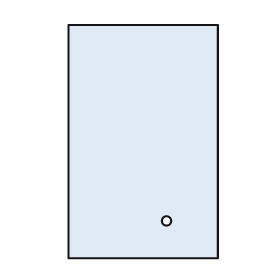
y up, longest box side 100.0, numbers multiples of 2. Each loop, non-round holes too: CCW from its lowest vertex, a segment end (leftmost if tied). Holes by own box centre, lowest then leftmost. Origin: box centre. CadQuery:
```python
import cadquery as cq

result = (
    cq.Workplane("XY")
    .moveTo(-32.0, -50.0)
    .lineTo(32.0, -50.0)
    .lineTo(32.0, 50.0)
    .lineTo(-32.0, 50.0)
    .close()
    .moveTo(10.0, -34.0)
    .circle(2.0)
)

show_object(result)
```